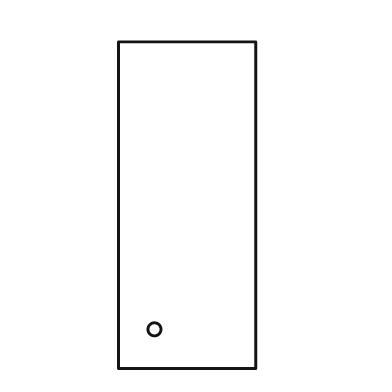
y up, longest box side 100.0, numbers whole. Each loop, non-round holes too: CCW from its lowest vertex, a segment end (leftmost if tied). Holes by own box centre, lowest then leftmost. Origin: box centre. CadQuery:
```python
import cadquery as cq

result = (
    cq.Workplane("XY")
    .moveTo(-21.0, -50.0)
    .lineTo(21.0, -50.0)
    .lineTo(21.0, 50.0)
    .lineTo(-21.0, 50.0)
    .close()
    .moveTo(-10.0, -38.0)
    .circle(2.0)
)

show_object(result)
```